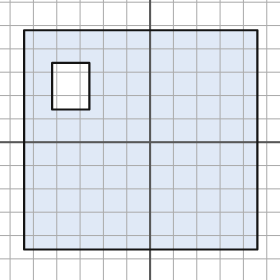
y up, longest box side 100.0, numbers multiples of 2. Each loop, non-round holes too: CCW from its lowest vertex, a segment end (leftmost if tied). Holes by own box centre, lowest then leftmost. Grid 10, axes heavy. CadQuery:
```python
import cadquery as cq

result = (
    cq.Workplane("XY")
    .moveTo(-54.0, -46.0)
    .lineTo(46.0, -46.0)
    .lineTo(46.0, 48.0)
    .lineTo(-54.0, 48.0)
    .close()
    .moveTo(-42.0, 14.0)
    .lineTo(-26.0, 14.0)
    .lineTo(-26.0, 34.0)
    .lineTo(-42.0, 34.0)
    .close()
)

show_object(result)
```